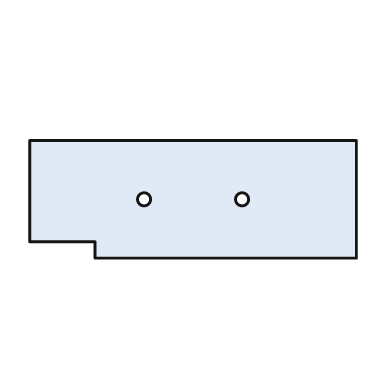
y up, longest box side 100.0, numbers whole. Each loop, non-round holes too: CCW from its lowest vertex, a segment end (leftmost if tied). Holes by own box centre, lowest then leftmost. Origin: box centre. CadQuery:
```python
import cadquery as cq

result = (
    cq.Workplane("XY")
    .moveTo(-30.0, -18.0)
    .lineTo(50.0, -18.0)
    .lineTo(50.0, 18.0)
    .lineTo(-50.0, 18.0)
    .lineTo(-50.0, -13.0)
    .lineTo(-30.0, -13.0)
    .close()
    .moveTo(-15.0, 0.0)
    .circle(2.0)
    .moveTo(15.0, 0.0)
    .circle(2.0)
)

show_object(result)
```